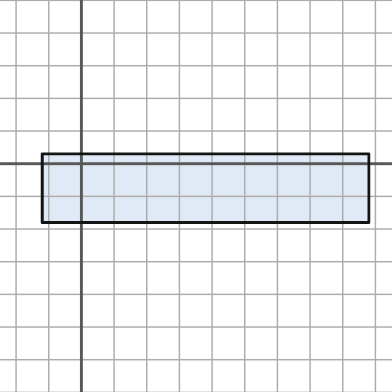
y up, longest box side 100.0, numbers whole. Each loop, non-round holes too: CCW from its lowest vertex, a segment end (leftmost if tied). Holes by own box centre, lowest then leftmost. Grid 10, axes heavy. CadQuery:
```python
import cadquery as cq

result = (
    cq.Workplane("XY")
    .moveTo(-12.0, -18.0)
    .lineTo(88.0, -18.0)
    .lineTo(88.0, 3.0)
    .lineTo(-12.0, 3.0)
    .close()
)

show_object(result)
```